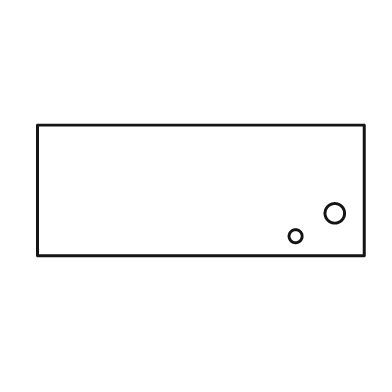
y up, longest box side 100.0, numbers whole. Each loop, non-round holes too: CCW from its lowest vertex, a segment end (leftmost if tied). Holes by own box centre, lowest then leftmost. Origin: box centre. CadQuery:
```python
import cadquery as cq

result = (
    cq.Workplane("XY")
    .moveTo(-50.0, -20.0)
    .lineTo(50.0, -20.0)
    .lineTo(50.0, 20.0)
    .lineTo(-50.0, 20.0)
    .close()
    .moveTo(29.0, -14.0)
    .circle(2.0)
    .moveTo(41.0, -7.0)
    .circle(3.0)
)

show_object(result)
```